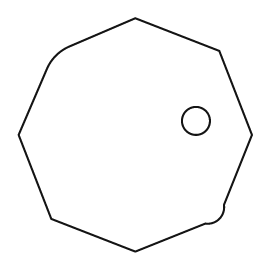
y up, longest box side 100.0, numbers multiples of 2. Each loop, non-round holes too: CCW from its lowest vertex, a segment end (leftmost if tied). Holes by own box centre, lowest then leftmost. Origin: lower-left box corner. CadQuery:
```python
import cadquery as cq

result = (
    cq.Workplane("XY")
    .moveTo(50.0, 0.0)
    .lineTo(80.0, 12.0)
    .threePointArc((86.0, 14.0), (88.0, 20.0))
    .lineTo(100.0, 50.0)
    .lineTo(86.0, 86.0)
    .lineTo(50.0, 100.0)
    .lineTo(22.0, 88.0)
    .threePointArc((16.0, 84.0), (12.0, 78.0))
    .lineTo(0.0, 50.0)
    .lineTo(14.0, 14.0)
    .close()
    .moveTo(76.0, 56.0)
    .circle(6.0)
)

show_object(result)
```